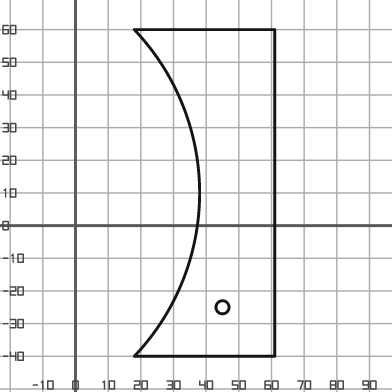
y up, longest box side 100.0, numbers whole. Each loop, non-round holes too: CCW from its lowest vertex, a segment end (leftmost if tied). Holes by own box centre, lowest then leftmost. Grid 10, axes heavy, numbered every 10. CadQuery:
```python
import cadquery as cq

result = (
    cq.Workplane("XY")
    .moveTo(18.0, -40.0)
    .lineTo(61.0, -40.0)
    .lineTo(61.0, 60.0)
    .lineTo(18.0, 60.0)
    .threePointArc((38.0, 10.0), (18.0, -40.0))
    .close()
    .moveTo(45.0, -25.0)
    .circle(2.0)
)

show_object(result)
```